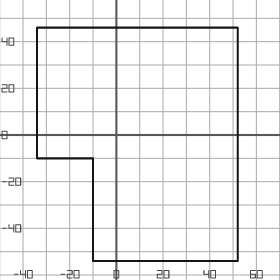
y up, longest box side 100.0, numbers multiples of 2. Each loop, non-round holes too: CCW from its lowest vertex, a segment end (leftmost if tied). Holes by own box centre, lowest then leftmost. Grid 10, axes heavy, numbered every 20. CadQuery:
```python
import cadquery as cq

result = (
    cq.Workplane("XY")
    .moveTo(-10.0, -54.0)
    .lineTo(52.0, -54.0)
    .lineTo(52.0, 46.0)
    .lineTo(-34.0, 46.0)
    .lineTo(-34.0, -10.0)
    .lineTo(-10.0, -10.0)
    .close()
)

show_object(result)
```